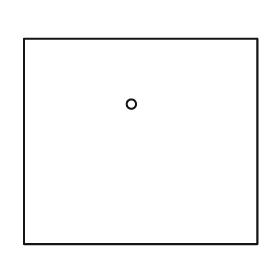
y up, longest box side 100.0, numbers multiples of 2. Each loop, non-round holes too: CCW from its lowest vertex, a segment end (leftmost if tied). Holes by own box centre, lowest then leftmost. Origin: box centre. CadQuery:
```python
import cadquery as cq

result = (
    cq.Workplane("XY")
    .moveTo(-50.0, -44.0)
    .lineTo(50.0, -44.0)
    .lineTo(50.0, 44.0)
    .lineTo(-50.0, 44.0)
    .close()
    .moveTo(-4.0, 16.0)
    .circle(2.0)
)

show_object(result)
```